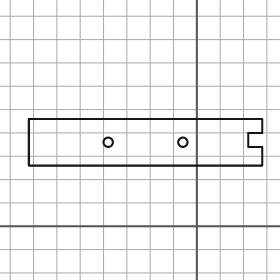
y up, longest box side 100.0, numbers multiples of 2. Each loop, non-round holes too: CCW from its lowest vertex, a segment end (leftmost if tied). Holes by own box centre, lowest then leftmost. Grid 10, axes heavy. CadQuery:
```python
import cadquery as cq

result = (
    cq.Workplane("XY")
    .moveTo(-72.0, 26.0)
    .lineTo(28.0, 26.0)
    .lineTo(28.0, 34.0)
    .lineTo(22.0, 34.0)
    .lineTo(22.0, 40.0)
    .lineTo(28.0, 40.0)
    .lineTo(28.0, 46.0)
    .lineTo(-72.0, 46.0)
    .close()
    .moveTo(-38.0, 36.0)
    .circle(2.0)
    .moveTo(-6.0, 36.0)
    .circle(2.0)
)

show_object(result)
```